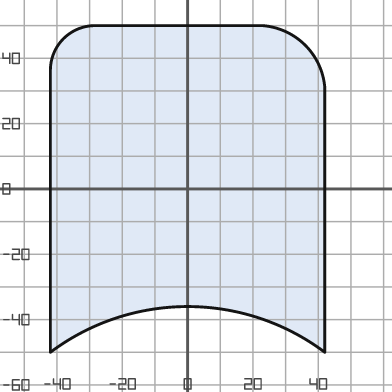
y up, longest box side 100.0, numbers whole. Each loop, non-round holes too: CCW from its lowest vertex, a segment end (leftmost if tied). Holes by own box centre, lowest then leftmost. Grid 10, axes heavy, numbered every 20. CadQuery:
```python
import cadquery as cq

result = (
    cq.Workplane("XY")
    .moveTo(-42.0, -50.0)
    .threePointArc((0.0, -36.0), (42.0, -50.0))
    .lineTo(42.0, 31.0)
    .threePointArc((36.0, 44.0), (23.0, 50.0))
    .lineTo(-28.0, 50.0)
    .threePointArc((-38.0, 46.0), (-42.0, 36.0))
    .close()
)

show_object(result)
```